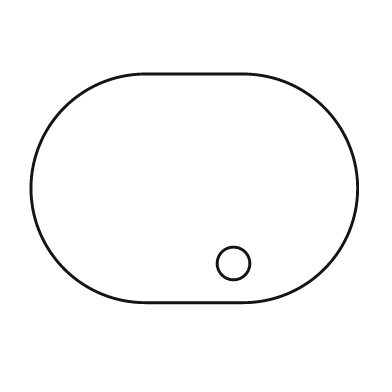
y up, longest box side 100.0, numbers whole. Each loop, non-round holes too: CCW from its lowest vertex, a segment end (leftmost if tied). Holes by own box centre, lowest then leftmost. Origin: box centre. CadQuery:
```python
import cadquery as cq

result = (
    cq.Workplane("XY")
    .moveTo(-15.0, -35.0)
    .lineTo(15.0, -35.0)
    .threePointArc((50.0, 0.0), (15.0, 35.0))
    .lineTo(-15.0, 35.0)
    .threePointArc((-50.0, 0.0), (-15.0, -35.0))
    .close()
    .moveTo(12.0, -23.0)
    .circle(5.0)
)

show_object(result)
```